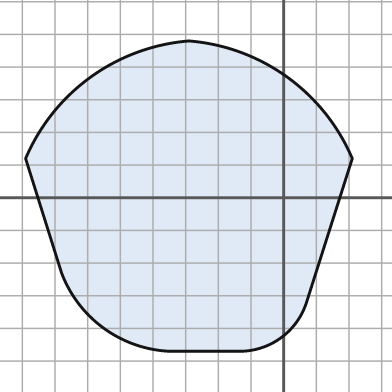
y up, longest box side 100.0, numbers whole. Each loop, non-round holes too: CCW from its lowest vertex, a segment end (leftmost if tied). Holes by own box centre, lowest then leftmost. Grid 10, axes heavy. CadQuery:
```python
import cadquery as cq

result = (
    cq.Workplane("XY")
    .moveTo(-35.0, -47.0)
    .lineTo(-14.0, -47.0)
    .threePointArc((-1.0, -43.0), (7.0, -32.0))
    .lineTo(21.0, 12.0)
    .threePointArc((1.0, 37.0), (-29.0, 48.0))
    .threePointArc((-59.0, 37.0), (-79.0, 12.0))
    .lineTo(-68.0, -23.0)
    .threePointArc((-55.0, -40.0), (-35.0, -47.0))
    .close()
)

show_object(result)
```